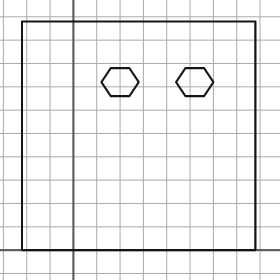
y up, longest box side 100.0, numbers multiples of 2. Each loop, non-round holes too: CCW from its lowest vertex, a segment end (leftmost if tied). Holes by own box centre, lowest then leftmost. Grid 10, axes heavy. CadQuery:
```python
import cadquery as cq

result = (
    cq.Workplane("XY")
    .moveTo(-22.0, 0.0)
    .lineTo(78.0, 0.0)
    .lineTo(78.0, 98.0)
    .lineTo(-22.0, 98.0)
    .close()
    .moveTo(16.0, 66.0)
    .lineTo(24.0, 66.0)
    .lineTo(28.0, 72.0)
    .lineTo(24.0, 78.0)
    .lineTo(16.0, 78.0)
    .lineTo(12.0, 72.0)
    .close()
    .moveTo(48.0, 66.0)
    .lineTo(56.0, 66.0)
    .lineTo(60.0, 72.0)
    .lineTo(56.0, 78.0)
    .lineTo(48.0, 78.0)
    .lineTo(44.0, 72.0)
    .close()
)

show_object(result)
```